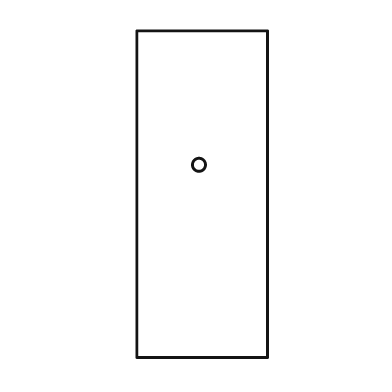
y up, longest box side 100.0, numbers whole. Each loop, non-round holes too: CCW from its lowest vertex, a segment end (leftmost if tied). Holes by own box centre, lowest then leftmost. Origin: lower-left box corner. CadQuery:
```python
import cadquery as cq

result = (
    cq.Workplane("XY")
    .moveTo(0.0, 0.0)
    .lineTo(40.0, 0.0)
    .lineTo(40.0, 100.0)
    .lineTo(0.0, 100.0)
    .close()
    .moveTo(19.0, 59.0)
    .circle(2.0)
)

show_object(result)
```